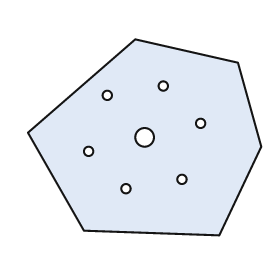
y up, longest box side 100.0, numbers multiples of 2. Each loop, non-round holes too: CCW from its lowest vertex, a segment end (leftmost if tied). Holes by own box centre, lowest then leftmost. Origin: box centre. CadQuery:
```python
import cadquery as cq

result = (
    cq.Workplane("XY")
    .moveTo(32.0, -42.0)
    .lineTo(50.0, -4.0)
    .lineTo(40.0, 32.0)
    .lineTo(-4.0, 42.0)
    .lineTo(-50.0, 2.0)
    .lineTo(-26.0, -40.0)
    .close()
    .moveTo(-8.0, -22.0)
    .circle(2.0)
    .moveTo(16.0, -18.0)
    .circle(2.0)
    .moveTo(-24.0, -6.0)
    .circle(2.0)
    .moveTo(0.0, 0.0)
    .circle(4.0)
    .moveTo(24.0, 6.0)
    .circle(2.0)
    .moveTo(-16.0, 18.0)
    .circle(2.0)
    .moveTo(8.0, 22.0)
    .circle(2.0)
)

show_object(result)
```